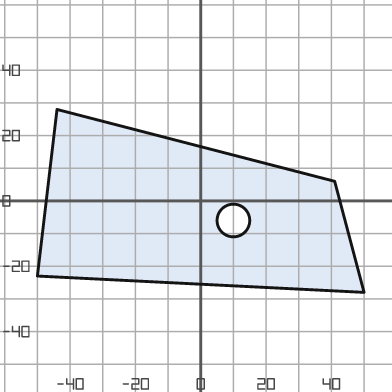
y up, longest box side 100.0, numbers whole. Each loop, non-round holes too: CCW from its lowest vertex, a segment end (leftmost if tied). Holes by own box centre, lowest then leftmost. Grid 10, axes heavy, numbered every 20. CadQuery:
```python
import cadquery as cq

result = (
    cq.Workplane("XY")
    .moveTo(50.0, -28.0)
    .lineTo(41.0, 6.0)
    .lineTo(-44.0, 28.0)
    .lineTo(-50.0, -23.0)
    .close()
    .moveTo(10.0, -6.0)
    .circle(5.0)
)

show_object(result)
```